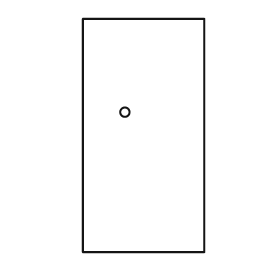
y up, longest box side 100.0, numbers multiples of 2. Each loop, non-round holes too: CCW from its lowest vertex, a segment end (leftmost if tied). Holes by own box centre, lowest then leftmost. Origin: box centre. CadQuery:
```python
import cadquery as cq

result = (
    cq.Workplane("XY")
    .moveTo(-26.0, -50.0)
    .lineTo(26.0, -50.0)
    .lineTo(26.0, 50.0)
    .lineTo(-26.0, 50.0)
    .close()
    .moveTo(-8.0, 10.0)
    .circle(2.0)
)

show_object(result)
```